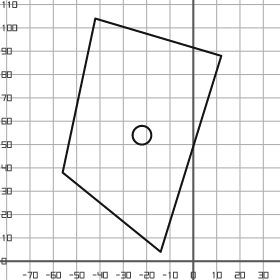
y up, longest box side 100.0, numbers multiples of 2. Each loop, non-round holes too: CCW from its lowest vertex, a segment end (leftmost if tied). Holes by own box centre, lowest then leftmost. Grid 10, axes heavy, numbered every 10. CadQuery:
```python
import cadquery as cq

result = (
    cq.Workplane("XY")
    .moveTo(-14.0, 4.0)
    .lineTo(12.0, 88.0)
    .lineTo(-42.0, 104.0)
    .lineTo(-56.0, 38.0)
    .close()
    .moveTo(-22.0, 54.0)
    .circle(4.0)
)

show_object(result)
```